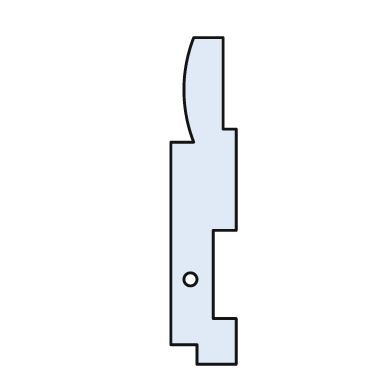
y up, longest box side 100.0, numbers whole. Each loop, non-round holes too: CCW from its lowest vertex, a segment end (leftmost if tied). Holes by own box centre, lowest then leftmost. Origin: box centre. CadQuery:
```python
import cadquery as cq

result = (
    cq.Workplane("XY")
    .moveTo(-2.0, -50.0)
    .lineTo(10.0, -50.0)
    .lineTo(10.0, -36.0)
    .lineTo(3.0, -36.0)
    .lineTo(3.0, -9.0)
    .lineTo(10.0, -9.0)
    .lineTo(10.0, 22.0)
    .lineTo(6.0, 22.0)
    .lineTo(6.0, 50.0)
    .lineTo(-3.0, 50.0)
    .threePointArc((-6.0, 34.0), (-3.0, 18.0))
    .lineTo(-10.0, 18.0)
    .lineTo(-10.0, -44.0)
    .lineTo(-2.0, -44.0)
    .close()
    .moveTo(-4.0, -24.0)
    .circle(2.0)
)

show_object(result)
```